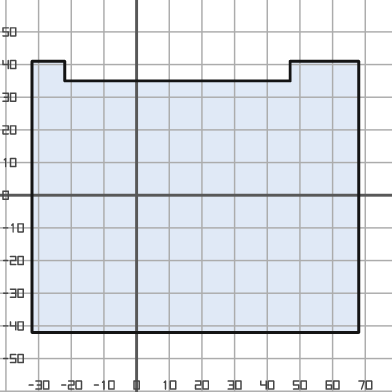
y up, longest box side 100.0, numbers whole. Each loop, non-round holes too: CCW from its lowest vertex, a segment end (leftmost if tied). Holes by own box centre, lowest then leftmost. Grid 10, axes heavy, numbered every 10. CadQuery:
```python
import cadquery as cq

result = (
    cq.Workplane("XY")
    .moveTo(-32.0, -42.0)
    .lineTo(68.0, -42.0)
    .lineTo(68.0, 41.0)
    .lineTo(47.0, 41.0)
    .lineTo(47.0, 35.0)
    .lineTo(-22.0, 35.0)
    .lineTo(-22.0, 41.0)
    .lineTo(-32.0, 41.0)
    .close()
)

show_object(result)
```